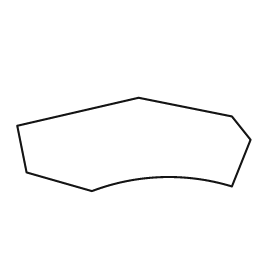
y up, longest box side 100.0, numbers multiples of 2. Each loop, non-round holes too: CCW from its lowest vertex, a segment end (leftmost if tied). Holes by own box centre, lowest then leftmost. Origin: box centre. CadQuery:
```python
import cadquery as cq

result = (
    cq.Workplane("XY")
    .moveTo(-18.0, -20.0)
    .threePointArc((12.0, -14.0), (42.0, -18.0))
    .lineTo(50.0, 2.0)
    .lineTo(42.0, 12.0)
    .lineTo(2.0, 20.0)
    .lineTo(-50.0, 8.0)
    .lineTo(-46.0, -12.0)
    .close()
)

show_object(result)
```